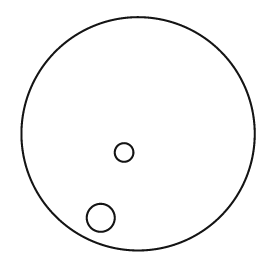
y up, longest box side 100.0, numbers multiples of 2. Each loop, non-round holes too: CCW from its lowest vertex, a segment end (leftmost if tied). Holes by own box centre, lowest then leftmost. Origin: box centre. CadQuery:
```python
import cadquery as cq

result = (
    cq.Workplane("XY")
    .moveTo(0.0, 0.0)
    .circle(50.0)
    .moveTo(-16.0, -36.0)
    .circle(6.0)
    .moveTo(-6.0, -8.0)
    .circle(4.0)
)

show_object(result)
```